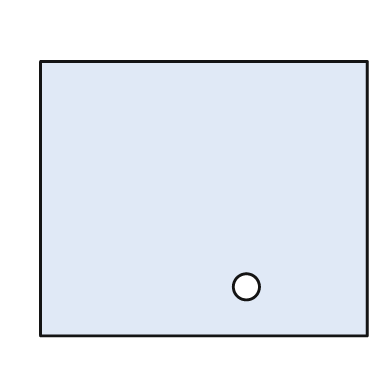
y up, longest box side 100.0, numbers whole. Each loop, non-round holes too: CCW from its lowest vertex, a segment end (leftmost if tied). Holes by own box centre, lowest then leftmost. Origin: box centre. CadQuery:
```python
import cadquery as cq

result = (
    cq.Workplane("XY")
    .moveTo(-50.0, -42.0)
    .lineTo(50.0, -42.0)
    .lineTo(50.0, 42.0)
    .lineTo(-50.0, 42.0)
    .close()
    .moveTo(13.0, -27.0)
    .circle(4.0)
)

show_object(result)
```